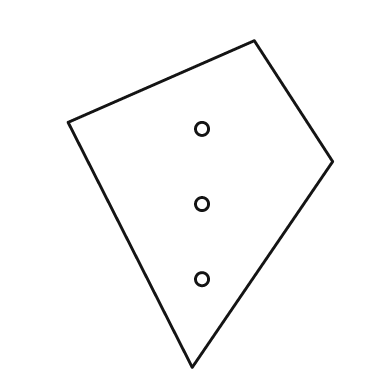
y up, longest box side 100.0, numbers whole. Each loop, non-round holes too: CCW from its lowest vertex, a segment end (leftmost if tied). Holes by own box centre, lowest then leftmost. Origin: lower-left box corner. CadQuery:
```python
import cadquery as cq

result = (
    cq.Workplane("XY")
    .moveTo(38.0, 0.0)
    .lineTo(81.0, 63.0)
    .lineTo(57.0, 100.0)
    .lineTo(0.0, 75.0)
    .close()
    .moveTo(41.0, 27.0)
    .circle(2.0)
    .moveTo(41.0, 50.0)
    .circle(2.0)
    .moveTo(41.0, 73.0)
    .circle(2.0)
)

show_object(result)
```